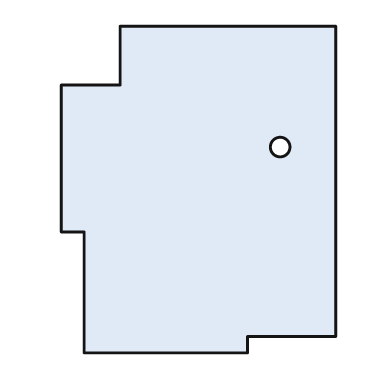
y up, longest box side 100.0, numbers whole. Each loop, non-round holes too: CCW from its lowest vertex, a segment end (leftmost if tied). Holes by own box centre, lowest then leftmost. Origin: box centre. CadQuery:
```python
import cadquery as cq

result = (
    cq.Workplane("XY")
    .moveTo(-35.0, -50.0)
    .lineTo(15.0, -50.0)
    .lineTo(15.0, -45.0)
    .lineTo(42.0, -45.0)
    .lineTo(42.0, 50.0)
    .lineTo(-24.0, 50.0)
    .lineTo(-24.0, 32.0)
    .lineTo(-42.0, 32.0)
    .lineTo(-42.0, -13.0)
    .lineTo(-35.0, -13.0)
    .close()
    .moveTo(25.0, 13.0)
    .circle(3.0)
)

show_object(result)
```